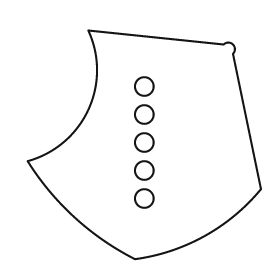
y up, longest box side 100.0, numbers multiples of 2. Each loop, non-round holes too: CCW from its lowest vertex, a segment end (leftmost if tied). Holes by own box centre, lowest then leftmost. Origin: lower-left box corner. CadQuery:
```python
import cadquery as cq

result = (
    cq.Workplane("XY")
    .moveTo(46.0, 0.0)
    .threePointArc((76.0, 10.0), (100.0, 30.0))
    .lineTo(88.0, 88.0)
    .threePointArc((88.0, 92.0), (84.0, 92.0))
    .lineTo(26.0, 98.0)
    .threePointArc((26.0, 64.0), (0.0, 42.0))
    .threePointArc((20.0, 18.0), (46.0, 0.0))
    .close()
    .moveTo(50.0, 26.0)
    .circle(4.0)
    .moveTo(50.0, 38.0)
    .circle(4.0)
    .moveTo(50.0, 50.0)
    .circle(4.0)
    .moveTo(50.0, 62.0)
    .circle(4.0)
    .moveTo(50.0, 74.0)
    .circle(4.0)
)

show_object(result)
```